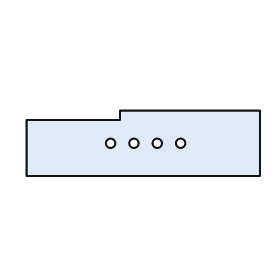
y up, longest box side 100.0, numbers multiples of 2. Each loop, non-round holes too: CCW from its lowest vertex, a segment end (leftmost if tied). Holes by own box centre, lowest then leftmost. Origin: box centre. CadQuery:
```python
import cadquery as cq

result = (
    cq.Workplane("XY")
    .moveTo(-50.0, -14.0)
    .lineTo(50.0, -14.0)
    .lineTo(50.0, 14.0)
    .lineTo(-10.0, 14.0)
    .lineTo(-10.0, 10.0)
    .lineTo(-50.0, 10.0)
    .close()
    .moveTo(-14.0, 0.0)
    .circle(2.0)
    .moveTo(-4.0, 0.0)
    .circle(2.0)
    .moveTo(6.0, 0.0)
    .circle(2.0)
    .moveTo(16.0, 0.0)
    .circle(2.0)
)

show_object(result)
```